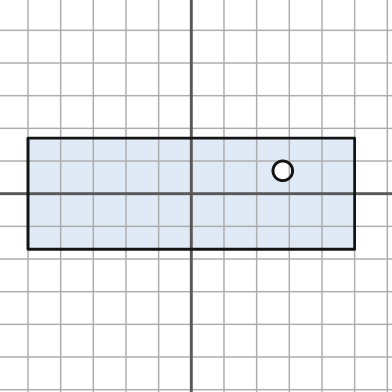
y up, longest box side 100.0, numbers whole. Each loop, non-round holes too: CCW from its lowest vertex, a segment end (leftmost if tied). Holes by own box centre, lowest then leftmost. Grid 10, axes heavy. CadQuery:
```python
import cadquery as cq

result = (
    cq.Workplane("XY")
    .moveTo(-50.0, -17.0)
    .lineTo(50.0, -17.0)
    .lineTo(50.0, 17.0)
    .lineTo(-50.0, 17.0)
    .close()
    .moveTo(28.0, 7.0)
    .circle(3.0)
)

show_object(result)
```